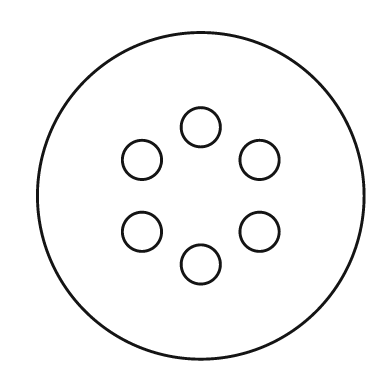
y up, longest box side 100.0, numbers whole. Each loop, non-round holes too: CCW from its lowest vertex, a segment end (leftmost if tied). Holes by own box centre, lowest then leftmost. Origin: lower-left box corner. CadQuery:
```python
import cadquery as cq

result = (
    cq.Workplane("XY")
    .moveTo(50.0, 50.0)
    .circle(50.0)
    .moveTo(50.0, 29.0)
    .circle(6.0)
    .moveTo(32.0, 39.0)
    .circle(6.0)
    .moveTo(68.0, 39.0)
    .circle(6.0)
    .moveTo(32.0, 61.0)
    .circle(6.0)
    .moveTo(68.0, 61.0)
    .circle(6.0)
    .moveTo(50.0, 71.0)
    .circle(6.0)
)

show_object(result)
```